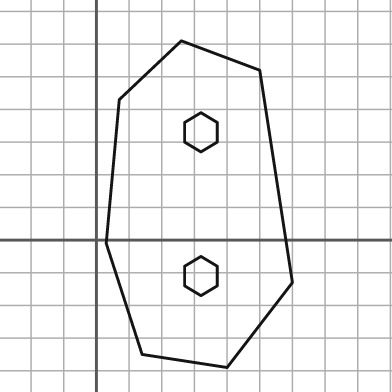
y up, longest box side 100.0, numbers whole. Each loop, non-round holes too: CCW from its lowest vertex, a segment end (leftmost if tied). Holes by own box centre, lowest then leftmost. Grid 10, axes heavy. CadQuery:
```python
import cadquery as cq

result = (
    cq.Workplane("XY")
    .moveTo(40.0, -39.0)
    .lineTo(60.0, -13.0)
    .lineTo(50.0, 52.0)
    .lineTo(26.0, 61.0)
    .lineTo(7.0, 43.0)
    .lineTo(3.0, -1.0)
    .lineTo(14.0, -35.0)
    .close()
    .moveTo(32.0, -17.0)
    .lineTo(37.0, -14.0)
    .lineTo(37.0, -8.0)
    .lineTo(32.0, -5.0)
    .lineTo(27.0, -8.0)
    .lineTo(27.0, -14.0)
    .close()
    .moveTo(32.0, 27.0)
    .lineTo(37.0, 30.0)
    .lineTo(37.0, 36.0)
    .lineTo(32.0, 39.0)
    .lineTo(27.0, 36.0)
    .lineTo(27.0, 30.0)
    .close()
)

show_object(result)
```